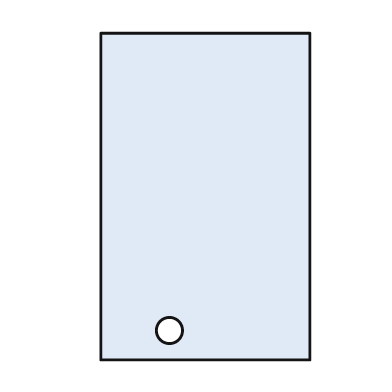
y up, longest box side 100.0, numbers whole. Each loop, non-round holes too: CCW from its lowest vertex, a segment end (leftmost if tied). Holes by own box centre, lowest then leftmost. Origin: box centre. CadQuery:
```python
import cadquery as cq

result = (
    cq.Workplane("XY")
    .moveTo(-32.0, -50.0)
    .lineTo(32.0, -50.0)
    .lineTo(32.0, 50.0)
    .lineTo(-32.0, 50.0)
    .close()
    .moveTo(-11.0, -41.0)
    .circle(4.0)
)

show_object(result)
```